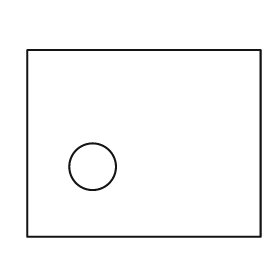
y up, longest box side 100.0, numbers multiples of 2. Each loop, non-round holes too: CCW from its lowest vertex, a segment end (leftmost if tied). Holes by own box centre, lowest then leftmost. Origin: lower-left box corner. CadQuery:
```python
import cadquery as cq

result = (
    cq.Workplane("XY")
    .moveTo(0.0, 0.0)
    .lineTo(100.0, 0.0)
    .lineTo(100.0, 80.0)
    .lineTo(0.0, 80.0)
    .close()
    .moveTo(28.0, 30.0)
    .circle(10.0)
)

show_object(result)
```